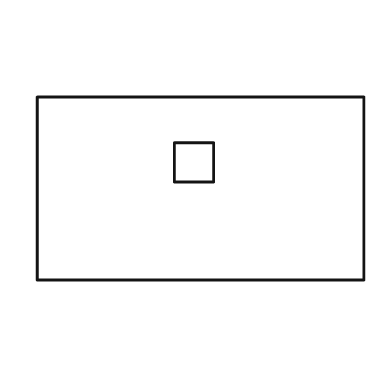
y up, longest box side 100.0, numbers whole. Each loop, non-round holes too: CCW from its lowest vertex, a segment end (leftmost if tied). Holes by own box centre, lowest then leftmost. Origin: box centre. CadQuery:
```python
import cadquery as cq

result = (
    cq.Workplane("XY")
    .moveTo(-50.0, -28.0)
    .lineTo(50.0, -28.0)
    .lineTo(50.0, 28.0)
    .lineTo(-50.0, 28.0)
    .close()
    .moveTo(-8.0, 2.0)
    .lineTo(4.0, 2.0)
    .lineTo(4.0, 14.0)
    .lineTo(-8.0, 14.0)
    .close()
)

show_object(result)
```